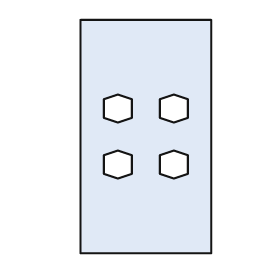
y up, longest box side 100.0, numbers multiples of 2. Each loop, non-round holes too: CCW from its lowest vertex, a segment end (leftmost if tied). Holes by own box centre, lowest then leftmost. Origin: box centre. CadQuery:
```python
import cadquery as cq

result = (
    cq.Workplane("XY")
    .moveTo(-28.0, -50.0)
    .lineTo(28.0, -50.0)
    .lineTo(28.0, 50.0)
    .lineTo(-28.0, 50.0)
    .close()
    .moveTo(-12.0, -18.0)
    .lineTo(-6.0, -16.0)
    .lineTo(-6.0, -8.0)
    .lineTo(-12.0, -6.0)
    .lineTo(-18.0, -8.0)
    .lineTo(-18.0, -16.0)
    .close()
    .moveTo(12.0, -18.0)
    .lineTo(18.0, -16.0)
    .lineTo(18.0, -8.0)
    .lineTo(12.0, -6.0)
    .lineTo(6.0, -8.0)
    .lineTo(6.0, -16.0)
    .close()
    .moveTo(-12.0, 6.0)
    .lineTo(-6.0, 8.0)
    .lineTo(-6.0, 16.0)
    .lineTo(-12.0, 18.0)
    .lineTo(-18.0, 16.0)
    .lineTo(-18.0, 8.0)
    .close()
    .moveTo(12.0, 6.0)
    .lineTo(18.0, 8.0)
    .lineTo(18.0, 16.0)
    .lineTo(12.0, 18.0)
    .lineTo(6.0, 16.0)
    .lineTo(6.0, 8.0)
    .close()
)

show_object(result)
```